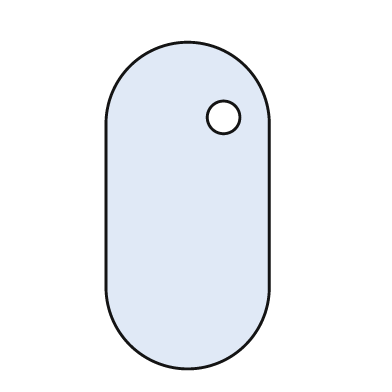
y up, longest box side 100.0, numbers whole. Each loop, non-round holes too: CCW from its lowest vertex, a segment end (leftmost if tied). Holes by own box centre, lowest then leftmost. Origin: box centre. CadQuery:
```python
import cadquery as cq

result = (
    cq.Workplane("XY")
    .moveTo(-25.0, -25.0)
    .threePointArc((0.0, -50.0), (25.0, -25.0))
    .lineTo(25.0, 25.0)
    .threePointArc((0.0, 50.0), (-25.0, 25.0))
    .close()
    .moveTo(11.0, 27.0)
    .circle(5.0)
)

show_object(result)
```